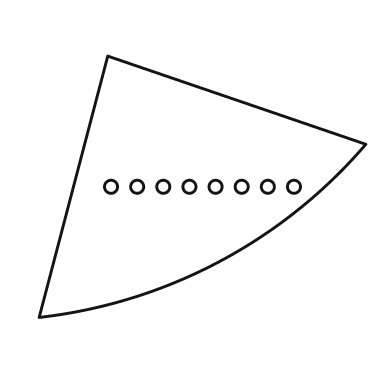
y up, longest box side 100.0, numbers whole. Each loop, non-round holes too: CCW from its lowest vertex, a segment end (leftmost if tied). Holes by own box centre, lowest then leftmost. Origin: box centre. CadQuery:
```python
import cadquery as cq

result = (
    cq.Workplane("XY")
    .moveTo(-50.0, -40.0)
    .threePointArc((5.0, -23.0), (50.0, 13.0))
    .lineTo(-29.0, 40.0)
    .close()
    .moveTo(-28.0, 0.0)
    .circle(2.0)
    .moveTo(-20.0, 0.0)
    .circle(2.0)
    .moveTo(-12.0, 0.0)
    .circle(2.0)
    .moveTo(-4.0, 0.0)
    .circle(2.0)
    .moveTo(4.0, 0.0)
    .circle(2.0)
    .moveTo(12.0, 0.0)
    .circle(2.0)
    .moveTo(20.0, 0.0)
    .circle(2.0)
    .moveTo(28.0, 0.0)
    .circle(2.0)
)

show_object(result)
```